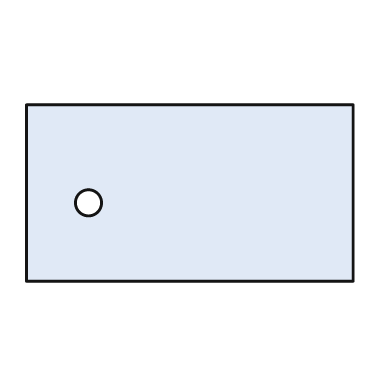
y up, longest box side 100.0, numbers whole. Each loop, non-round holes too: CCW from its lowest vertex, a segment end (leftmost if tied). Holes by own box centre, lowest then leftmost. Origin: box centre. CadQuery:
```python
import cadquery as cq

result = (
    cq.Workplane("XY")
    .moveTo(-50.0, -27.0)
    .lineTo(50.0, -27.0)
    .lineTo(50.0, 27.0)
    .lineTo(-50.0, 27.0)
    .close()
    .moveTo(-31.0, -3.0)
    .circle(4.0)
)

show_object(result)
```